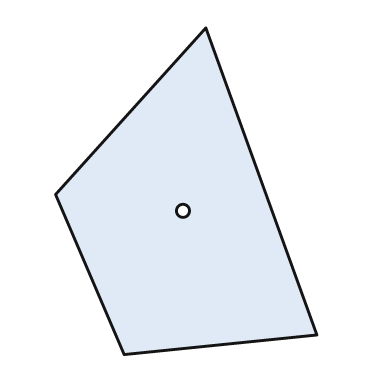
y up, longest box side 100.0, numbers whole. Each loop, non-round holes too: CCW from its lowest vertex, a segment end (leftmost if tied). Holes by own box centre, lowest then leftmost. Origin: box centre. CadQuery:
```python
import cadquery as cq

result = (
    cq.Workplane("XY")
    .moveTo(-19.0, -50.0)
    .lineTo(40.0, -44.0)
    .lineTo(6.0, 50.0)
    .lineTo(-40.0, -1.0)
    .close()
    .moveTo(-1.0, -6.0)
    .circle(2.0)
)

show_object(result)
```